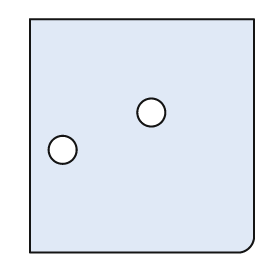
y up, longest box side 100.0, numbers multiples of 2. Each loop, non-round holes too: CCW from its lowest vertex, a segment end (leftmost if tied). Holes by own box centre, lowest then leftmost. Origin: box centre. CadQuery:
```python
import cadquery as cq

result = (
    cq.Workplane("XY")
    .moveTo(-48.0, -50.0)
    .lineTo(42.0, -50.0)
    .threePointArc((46.0, -48.0), (48.0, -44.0))
    .lineTo(48.0, 50.0)
    .lineTo(-48.0, 50.0)
    .close()
    .moveTo(-34.0, -6.0)
    .circle(6.0)
    .moveTo(4.0, 10.0)
    .circle(6.0)
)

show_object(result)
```